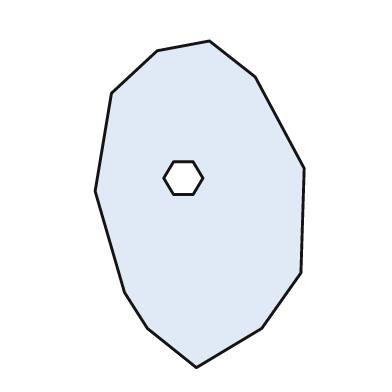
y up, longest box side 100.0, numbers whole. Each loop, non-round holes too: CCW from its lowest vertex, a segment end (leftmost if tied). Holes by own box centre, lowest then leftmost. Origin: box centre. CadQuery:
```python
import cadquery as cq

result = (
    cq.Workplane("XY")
    .moveTo(-1.0, -50.0)
    .lineTo(19.0, -38.0)
    .lineTo(31.0, -21.0)
    .lineTo(32.0, 11.0)
    .lineTo(17.0, 39.0)
    .lineTo(3.0, 50.0)
    .lineTo(-13.0, 47.0)
    .lineTo(-27.0, 34.0)
    .lineTo(-32.0, 4.0)
    .lineTo(-23.0, -27.0)
    .lineTo(-16.0, -38.0)
    .close()
    .moveTo(-8.0, 3.0)
    .lineTo(-2.0, 3.0)
    .lineTo(1.0, 8.0)
    .lineTo(-2.0, 13.0)
    .lineTo(-8.0, 13.0)
    .lineTo(-11.0, 8.0)
    .close()
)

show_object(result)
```